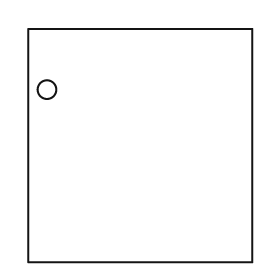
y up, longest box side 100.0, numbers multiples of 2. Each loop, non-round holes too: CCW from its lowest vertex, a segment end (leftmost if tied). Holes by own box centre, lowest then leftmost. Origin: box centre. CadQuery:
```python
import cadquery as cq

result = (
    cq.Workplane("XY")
    .moveTo(-48.0, -50.0)
    .lineTo(48.0, -50.0)
    .lineTo(48.0, 50.0)
    .lineTo(-48.0, 50.0)
    .close()
    .moveTo(-40.0, 24.0)
    .circle(4.0)
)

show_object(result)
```